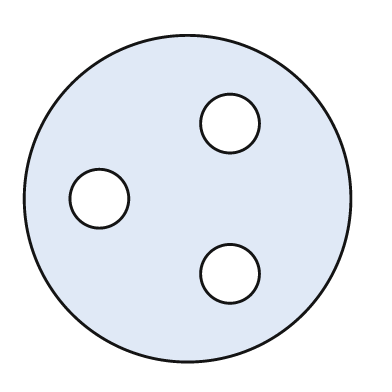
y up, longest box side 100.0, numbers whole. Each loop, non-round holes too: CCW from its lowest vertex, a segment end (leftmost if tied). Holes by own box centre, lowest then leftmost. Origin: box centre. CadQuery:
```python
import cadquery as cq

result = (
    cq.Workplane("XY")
    .moveTo(0.0, 0.0)
    .circle(50.0)
    .moveTo(13.0, -23.0)
    .circle(9.0)
    .moveTo(-27.0, 0.0)
    .circle(9.0)
    .moveTo(13.0, 23.0)
    .circle(9.0)
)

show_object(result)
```